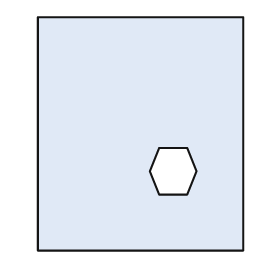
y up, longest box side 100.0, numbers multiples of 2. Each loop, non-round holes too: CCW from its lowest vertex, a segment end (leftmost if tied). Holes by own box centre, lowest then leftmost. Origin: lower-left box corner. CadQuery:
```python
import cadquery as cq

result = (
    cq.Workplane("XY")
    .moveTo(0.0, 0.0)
    .lineTo(88.0, 0.0)
    .lineTo(88.0, 100.0)
    .lineTo(0.0, 100.0)
    .close()
    .moveTo(52.0, 24.0)
    .lineTo(64.0, 24.0)
    .lineTo(68.0, 34.0)
    .lineTo(64.0, 44.0)
    .lineTo(52.0, 44.0)
    .lineTo(48.0, 34.0)
    .close()
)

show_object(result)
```